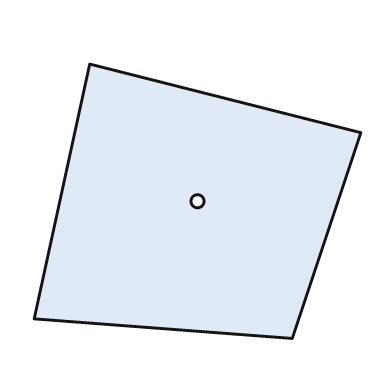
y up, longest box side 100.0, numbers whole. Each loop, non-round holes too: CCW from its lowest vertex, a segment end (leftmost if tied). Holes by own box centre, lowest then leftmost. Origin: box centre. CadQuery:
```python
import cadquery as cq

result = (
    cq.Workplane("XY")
    .moveTo(29.0, -42.0)
    .lineTo(50.0, 21.0)
    .lineTo(-33.0, 42.0)
    .lineTo(-50.0, -36.0)
    .close()
    .moveTo(0.0, 0.0)
    .circle(2.0)
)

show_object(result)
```